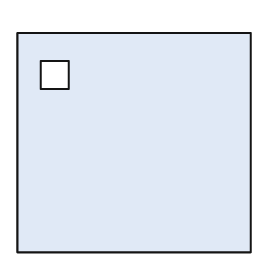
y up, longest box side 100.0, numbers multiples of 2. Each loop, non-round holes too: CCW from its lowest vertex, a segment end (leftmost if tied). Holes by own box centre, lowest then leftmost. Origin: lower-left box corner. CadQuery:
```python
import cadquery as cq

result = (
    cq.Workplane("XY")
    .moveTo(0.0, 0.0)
    .lineTo(100.0, 0.0)
    .lineTo(100.0, 94.0)
    .lineTo(0.0, 94.0)
    .close()
    .moveTo(10.0, 70.0)
    .lineTo(22.0, 70.0)
    .lineTo(22.0, 82.0)
    .lineTo(10.0, 82.0)
    .close()
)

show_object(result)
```